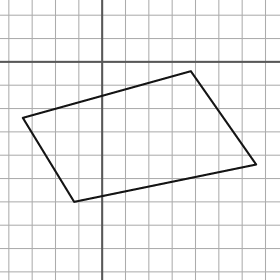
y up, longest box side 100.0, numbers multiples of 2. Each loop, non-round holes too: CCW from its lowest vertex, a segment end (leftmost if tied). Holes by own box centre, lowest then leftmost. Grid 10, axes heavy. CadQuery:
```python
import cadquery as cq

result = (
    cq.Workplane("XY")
    .moveTo(-12.0, -60.0)
    .lineTo(66.0, -44.0)
    .lineTo(38.0, -4.0)
    .lineTo(-34.0, -24.0)
    .close()
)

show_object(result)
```